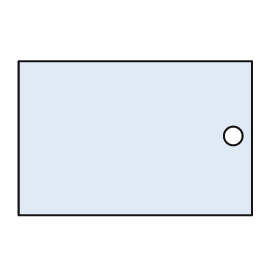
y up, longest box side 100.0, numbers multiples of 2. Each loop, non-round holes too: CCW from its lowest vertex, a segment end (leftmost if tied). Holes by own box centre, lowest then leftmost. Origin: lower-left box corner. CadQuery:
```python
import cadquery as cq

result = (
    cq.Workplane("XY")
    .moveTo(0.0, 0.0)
    .lineTo(100.0, 0.0)
    .lineTo(100.0, 66.0)
    .lineTo(0.0, 66.0)
    .close()
    .moveTo(92.0, 34.0)
    .circle(4.0)
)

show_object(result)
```